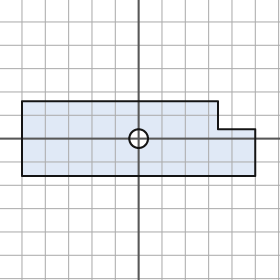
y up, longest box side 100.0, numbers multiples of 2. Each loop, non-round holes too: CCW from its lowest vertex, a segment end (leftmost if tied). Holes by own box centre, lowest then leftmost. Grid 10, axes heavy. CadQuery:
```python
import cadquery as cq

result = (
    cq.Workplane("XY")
    .moveTo(-50.0, -16.0)
    .lineTo(50.0, -16.0)
    .lineTo(50.0, 4.0)
    .lineTo(34.0, 4.0)
    .lineTo(34.0, 16.0)
    .lineTo(-50.0, 16.0)
    .close()
    .moveTo(0.0, 0.0)
    .circle(4.0)
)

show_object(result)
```